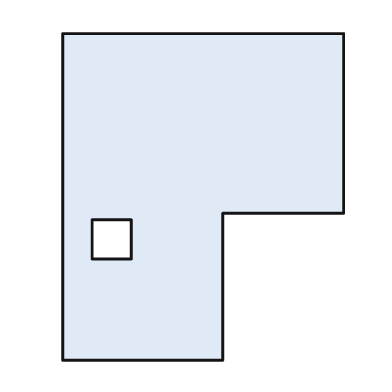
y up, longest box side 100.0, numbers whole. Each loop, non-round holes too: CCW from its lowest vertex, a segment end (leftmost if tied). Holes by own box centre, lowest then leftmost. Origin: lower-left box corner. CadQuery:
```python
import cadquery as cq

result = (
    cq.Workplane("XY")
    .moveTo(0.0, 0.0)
    .lineTo(49.0, 0.0)
    .lineTo(49.0, 45.0)
    .lineTo(86.0, 45.0)
    .lineTo(86.0, 100.0)
    .lineTo(0.0, 100.0)
    .close()
    .moveTo(9.0, 31.0)
    .lineTo(21.0, 31.0)
    .lineTo(21.0, 43.0)
    .lineTo(9.0, 43.0)
    .close()
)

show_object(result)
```